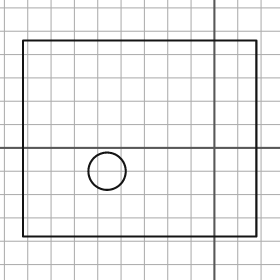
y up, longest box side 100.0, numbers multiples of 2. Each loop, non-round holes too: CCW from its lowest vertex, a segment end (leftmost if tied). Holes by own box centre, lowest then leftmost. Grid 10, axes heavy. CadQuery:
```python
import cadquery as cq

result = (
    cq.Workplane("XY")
    .moveTo(-82.0, -38.0)
    .lineTo(18.0, -38.0)
    .lineTo(18.0, 46.0)
    .lineTo(-82.0, 46.0)
    .close()
    .moveTo(-46.0, -10.0)
    .circle(8.0)
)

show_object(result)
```